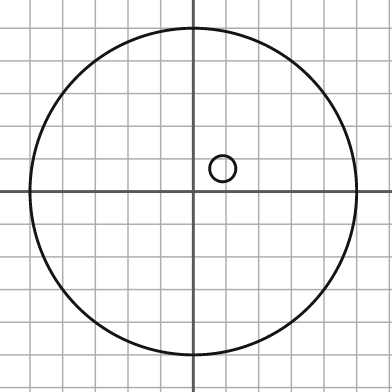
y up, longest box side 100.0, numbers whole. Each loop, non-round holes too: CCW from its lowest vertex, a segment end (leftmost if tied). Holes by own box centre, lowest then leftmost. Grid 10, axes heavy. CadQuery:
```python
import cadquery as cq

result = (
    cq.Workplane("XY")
    .moveTo(0.0, 0.0)
    .circle(50.0)
    .moveTo(9.0, 7.0)
    .circle(4.0)
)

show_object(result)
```